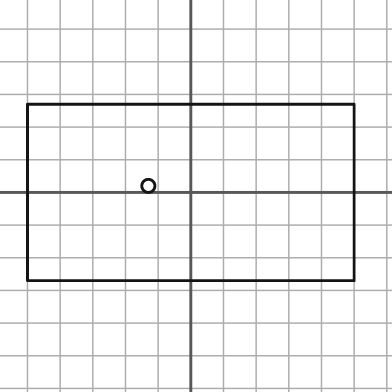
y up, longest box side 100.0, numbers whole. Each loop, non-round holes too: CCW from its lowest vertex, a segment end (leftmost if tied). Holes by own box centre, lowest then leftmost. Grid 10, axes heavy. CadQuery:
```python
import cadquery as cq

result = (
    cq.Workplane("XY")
    .moveTo(-50.0, -27.0)
    .lineTo(50.0, -27.0)
    .lineTo(50.0, 27.0)
    .lineTo(-50.0, 27.0)
    .close()
    .moveTo(-13.0, 2.0)
    .circle(2.0)
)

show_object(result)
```